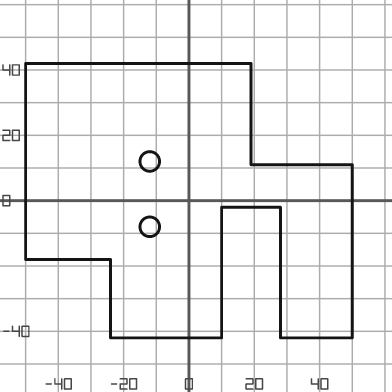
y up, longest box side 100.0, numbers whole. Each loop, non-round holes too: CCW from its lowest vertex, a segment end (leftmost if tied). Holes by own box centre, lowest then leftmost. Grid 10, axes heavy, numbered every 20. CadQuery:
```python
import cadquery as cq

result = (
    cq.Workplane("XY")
    .moveTo(-24.0, -42.0)
    .lineTo(10.0, -42.0)
    .lineTo(10.0, -2.0)
    .lineTo(28.0, -2.0)
    .lineTo(28.0, -42.0)
    .lineTo(50.0, -42.0)
    .lineTo(50.0, 11.0)
    .lineTo(19.0, 11.0)
    .lineTo(19.0, 42.0)
    .lineTo(-50.0, 42.0)
    .lineTo(-50.0, -18.0)
    .lineTo(-24.0, -18.0)
    .close()
    .moveTo(-12.0, -8.0)
    .circle(3.0)
    .moveTo(-12.0, 12.0)
    .circle(3.0)
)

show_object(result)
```